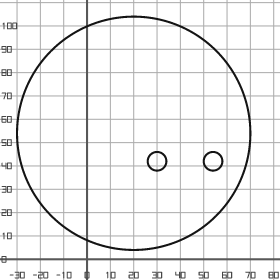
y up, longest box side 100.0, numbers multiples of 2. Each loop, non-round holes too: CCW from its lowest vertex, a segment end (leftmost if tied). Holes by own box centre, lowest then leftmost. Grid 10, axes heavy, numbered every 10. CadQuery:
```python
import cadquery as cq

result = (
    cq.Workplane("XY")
    .moveTo(20.0, 54.0)
    .circle(50.0)
    .moveTo(30.0, 42.0)
    .circle(4.0)
    .moveTo(54.0, 42.0)
    .circle(4.0)
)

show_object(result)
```